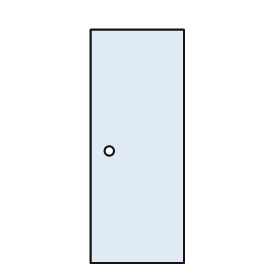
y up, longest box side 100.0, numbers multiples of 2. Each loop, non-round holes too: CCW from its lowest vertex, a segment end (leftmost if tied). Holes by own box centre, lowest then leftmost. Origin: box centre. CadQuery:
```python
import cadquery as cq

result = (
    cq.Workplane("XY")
    .moveTo(-20.0, -50.0)
    .lineTo(20.0, -50.0)
    .lineTo(20.0, 50.0)
    .lineTo(-20.0, 50.0)
    .close()
    .moveTo(-12.0, -2.0)
    .circle(2.0)
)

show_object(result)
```